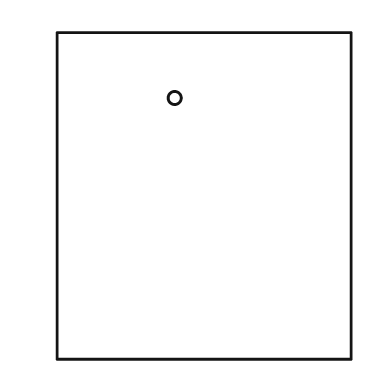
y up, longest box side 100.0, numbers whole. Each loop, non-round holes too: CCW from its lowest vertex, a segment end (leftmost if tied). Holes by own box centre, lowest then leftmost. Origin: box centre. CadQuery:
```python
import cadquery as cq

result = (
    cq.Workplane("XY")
    .moveTo(-45.0, -50.0)
    .lineTo(45.0, -50.0)
    .lineTo(45.0, 50.0)
    .lineTo(-45.0, 50.0)
    .close()
    .moveTo(-9.0, 30.0)
    .circle(2.0)
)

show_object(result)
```